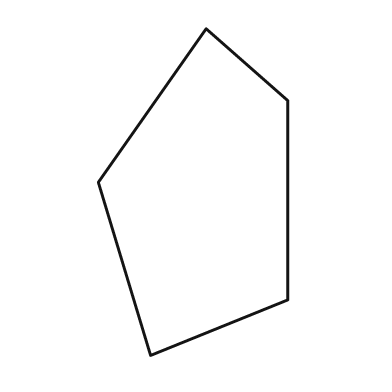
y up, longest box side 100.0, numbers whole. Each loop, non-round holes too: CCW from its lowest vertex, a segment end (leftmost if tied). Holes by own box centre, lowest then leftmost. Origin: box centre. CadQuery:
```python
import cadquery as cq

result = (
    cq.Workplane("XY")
    .moveTo(-13.0, -50.0)
    .lineTo(29.0, -33.0)
    .lineTo(29.0, 28.0)
    .lineTo(4.0, 50.0)
    .lineTo(-29.0, 3.0)
    .close()
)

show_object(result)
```